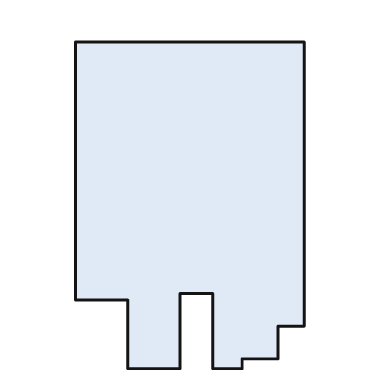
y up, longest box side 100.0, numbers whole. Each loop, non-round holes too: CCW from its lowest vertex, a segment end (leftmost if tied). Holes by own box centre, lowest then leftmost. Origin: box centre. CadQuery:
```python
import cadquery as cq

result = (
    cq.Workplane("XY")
    .moveTo(-19.0, -50.0)
    .lineTo(-3.0, -50.0)
    .lineTo(-3.0, -27.0)
    .lineTo(7.0, -27.0)
    .lineTo(7.0, -50.0)
    .lineTo(16.0, -50.0)
    .lineTo(16.0, -47.0)
    .lineTo(27.0, -47.0)
    .lineTo(27.0, -37.0)
    .lineTo(35.0, -37.0)
    .lineTo(35.0, 50.0)
    .lineTo(-35.0, 50.0)
    .lineTo(-35.0, -29.0)
    .lineTo(-19.0, -29.0)
    .close()
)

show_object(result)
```